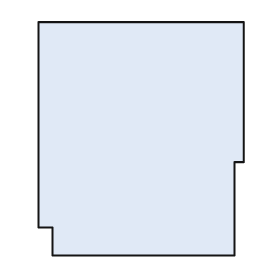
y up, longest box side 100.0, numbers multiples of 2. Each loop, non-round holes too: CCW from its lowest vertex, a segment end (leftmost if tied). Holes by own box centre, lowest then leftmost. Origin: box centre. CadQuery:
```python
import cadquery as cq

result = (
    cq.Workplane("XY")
    .moveTo(-38.0, -50.0)
    .lineTo(40.0, -50.0)
    .lineTo(40.0, -10.0)
    .lineTo(44.0, -10.0)
    .lineTo(44.0, 50.0)
    .lineTo(-44.0, 50.0)
    .lineTo(-44.0, -38.0)
    .lineTo(-38.0, -38.0)
    .close()
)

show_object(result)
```